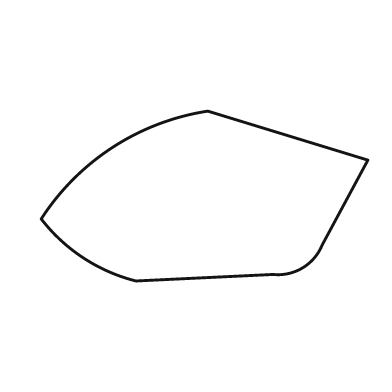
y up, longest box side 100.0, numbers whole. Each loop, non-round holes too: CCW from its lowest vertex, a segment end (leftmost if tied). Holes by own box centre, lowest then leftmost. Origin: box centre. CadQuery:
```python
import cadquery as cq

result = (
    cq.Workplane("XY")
    .moveTo(-21.0, -26.0)
    .lineTo(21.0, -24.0)
    .threePointArc((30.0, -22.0), (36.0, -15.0))
    .lineTo(50.0, 11.0)
    .lineTo(1.0, 26.0)
    .threePointArc((-28.0, 15.0), (-50.0, -7.0))
    .threePointArc((-37.0, -19.0), (-21.0, -26.0))
    .close()
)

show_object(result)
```